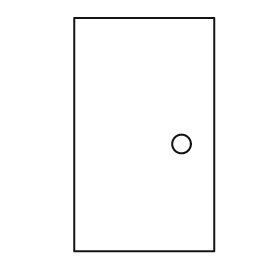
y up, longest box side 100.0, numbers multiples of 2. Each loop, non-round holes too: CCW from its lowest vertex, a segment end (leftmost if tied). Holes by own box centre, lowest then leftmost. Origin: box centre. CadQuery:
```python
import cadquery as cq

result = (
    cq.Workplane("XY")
    .moveTo(-30.0, -50.0)
    .lineTo(30.0, -50.0)
    .lineTo(30.0, 50.0)
    .lineTo(-30.0, 50.0)
    .close()
    .moveTo(16.0, -4.0)
    .circle(4.0)
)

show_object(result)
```